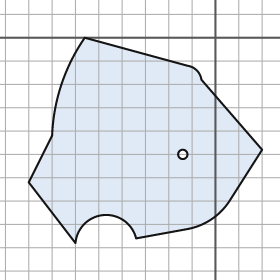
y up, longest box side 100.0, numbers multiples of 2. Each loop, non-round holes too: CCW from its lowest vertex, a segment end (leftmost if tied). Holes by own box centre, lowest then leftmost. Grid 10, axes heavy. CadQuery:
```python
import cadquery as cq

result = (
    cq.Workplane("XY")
    .moveTo(-60.0, -88.0)
    .threePointArc((-48.0, -76.0), (-34.0, -86.0))
    .lineTo(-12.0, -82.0)
    .threePointArc((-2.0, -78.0), (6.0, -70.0))
    .lineTo(20.0, -48.0)
    .lineTo(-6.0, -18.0)
    .threePointArc((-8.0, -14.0), (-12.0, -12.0))
    .lineTo(-56.0, 0.0)
    .threePointArc((-66.0, -20.0), (-70.0, -42.0))
    .lineTo(-80.0, -62.0)
    .close()
    .moveTo(-14.0, -50.0)
    .circle(2.0)
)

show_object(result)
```